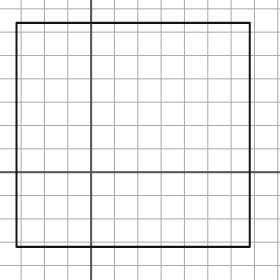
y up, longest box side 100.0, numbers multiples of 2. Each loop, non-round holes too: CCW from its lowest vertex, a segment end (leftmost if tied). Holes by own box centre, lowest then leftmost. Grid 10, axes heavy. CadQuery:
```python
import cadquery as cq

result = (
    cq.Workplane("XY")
    .moveTo(-32.0, -32.0)
    .lineTo(68.0, -32.0)
    .lineTo(68.0, 64.0)
    .lineTo(-32.0, 64.0)
    .close()
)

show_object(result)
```